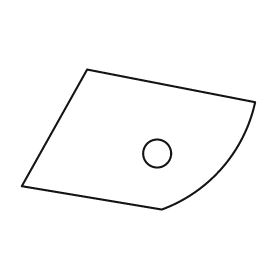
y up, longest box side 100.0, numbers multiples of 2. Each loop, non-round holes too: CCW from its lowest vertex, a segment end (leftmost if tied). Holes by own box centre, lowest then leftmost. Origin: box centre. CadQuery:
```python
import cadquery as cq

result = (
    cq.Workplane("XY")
    .moveTo(10.0, -30.0)
    .threePointArc((36.0, -12.0), (50.0, 16.0))
    .lineTo(-22.0, 30.0)
    .lineTo(-50.0, -20.0)
    .close()
    .moveTo(8.0, -6.0)
    .circle(6.0)
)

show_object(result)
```